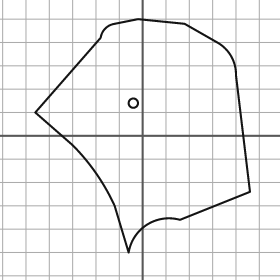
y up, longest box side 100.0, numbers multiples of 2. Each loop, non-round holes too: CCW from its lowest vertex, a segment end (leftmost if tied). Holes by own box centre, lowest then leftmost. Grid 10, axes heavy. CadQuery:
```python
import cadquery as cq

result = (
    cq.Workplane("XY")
    .moveTo(-6.0, -50.0)
    .threePointArc((2.0, -38.0), (16.0, -36.0))
    .lineTo(46.0, -24.0)
    .lineTo(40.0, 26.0)
    .threePointArc((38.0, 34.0), (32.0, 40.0))
    .lineTo(18.0, 48.0)
    .lineTo(-2.0, 50.0)
    .lineTo(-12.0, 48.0)
    .threePointArc((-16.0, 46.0), (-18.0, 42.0))
    .lineTo(-46.0, 10.0)
    .lineTo(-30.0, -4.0)
    .threePointArc((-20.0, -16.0), (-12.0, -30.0))
    .close()
    .moveTo(-4.0, 14.0)
    .circle(2.0)
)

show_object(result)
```